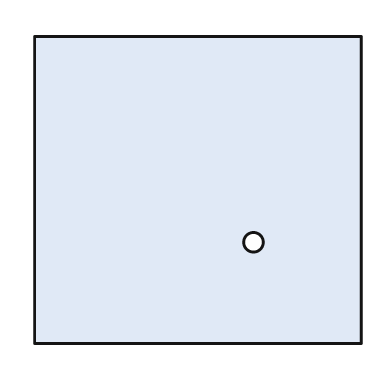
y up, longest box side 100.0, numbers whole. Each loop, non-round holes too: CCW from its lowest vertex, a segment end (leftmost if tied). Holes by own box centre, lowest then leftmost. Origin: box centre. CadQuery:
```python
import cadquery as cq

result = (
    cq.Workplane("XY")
    .moveTo(-50.0, -47.0)
    .lineTo(50.0, -47.0)
    .lineTo(50.0, 47.0)
    .lineTo(-50.0, 47.0)
    .close()
    .moveTo(17.0, -16.0)
    .circle(3.0)
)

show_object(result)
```